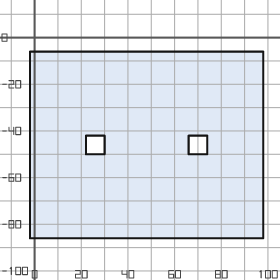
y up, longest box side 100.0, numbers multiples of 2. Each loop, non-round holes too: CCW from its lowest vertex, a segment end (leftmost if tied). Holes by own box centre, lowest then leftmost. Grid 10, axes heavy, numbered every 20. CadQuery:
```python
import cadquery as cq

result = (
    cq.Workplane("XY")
    .moveTo(-2.0, -86.0)
    .lineTo(98.0, -86.0)
    .lineTo(98.0, -6.0)
    .lineTo(-2.0, -6.0)
    .close()
    .moveTo(22.0, -50.0)
    .lineTo(30.0, -50.0)
    .lineTo(30.0, -42.0)
    .lineTo(22.0, -42.0)
    .close()
    .moveTo(66.0, -50.0)
    .lineTo(74.0, -50.0)
    .lineTo(74.0, -42.0)
    .lineTo(66.0, -42.0)
    .close()
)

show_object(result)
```